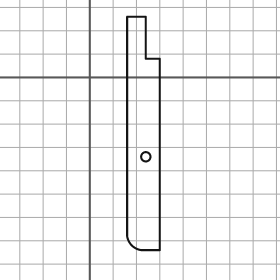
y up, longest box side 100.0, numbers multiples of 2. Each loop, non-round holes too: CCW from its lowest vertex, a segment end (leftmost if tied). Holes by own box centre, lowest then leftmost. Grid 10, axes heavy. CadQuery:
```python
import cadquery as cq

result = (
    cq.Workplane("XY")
    .moveTo(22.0, -74.0)
    .lineTo(30.0, -74.0)
    .lineTo(30.0, 8.0)
    .lineTo(24.0, 8.0)
    .lineTo(24.0, 26.0)
    .lineTo(16.0, 26.0)
    .lineTo(16.0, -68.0)
    .threePointArc((18.0, -72.0), (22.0, -74.0))
    .close()
    .moveTo(24.0, -34.0)
    .circle(2.0)
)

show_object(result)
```